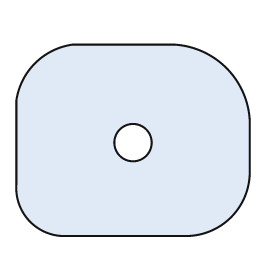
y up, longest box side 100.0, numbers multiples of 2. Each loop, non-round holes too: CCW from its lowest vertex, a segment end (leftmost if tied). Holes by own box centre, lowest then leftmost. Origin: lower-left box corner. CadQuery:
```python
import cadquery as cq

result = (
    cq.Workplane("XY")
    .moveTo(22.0, 0.0)
    .lineTo(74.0, 0.0)
    .threePointArc((92.0, 8.0), (100.0, 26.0))
    .lineTo(100.0, 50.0)
    .threePointArc((90.0, 72.0), (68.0, 82.0))
    .lineTo(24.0, 82.0)
    .threePointArc((8.0, 74.0), (0.0, 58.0))
    .lineTo(0.0, 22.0)
    .threePointArc((6.0, 6.0), (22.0, 0.0))
    .close()
    .moveTo(50.0, 40.0)
    .circle(8.0)
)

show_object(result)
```